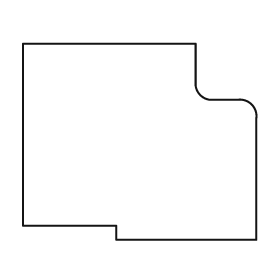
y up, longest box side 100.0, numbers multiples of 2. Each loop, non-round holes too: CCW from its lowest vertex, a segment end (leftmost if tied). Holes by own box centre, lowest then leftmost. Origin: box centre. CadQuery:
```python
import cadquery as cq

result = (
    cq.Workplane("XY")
    .moveTo(-10.0, -42.0)
    .lineTo(50.0, -42.0)
    .lineTo(50.0, 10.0)
    .threePointArc((48.0, 16.0), (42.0, 18.0))
    .lineTo(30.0, 18.0)
    .threePointArc((26.0, 20.0), (24.0, 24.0))
    .lineTo(24.0, 42.0)
    .lineTo(-50.0, 42.0)
    .lineTo(-50.0, -36.0)
    .lineTo(-10.0, -36.0)
    .close()
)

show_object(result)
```